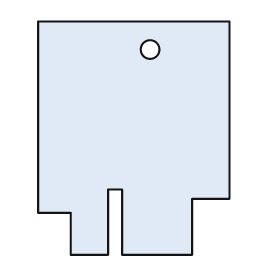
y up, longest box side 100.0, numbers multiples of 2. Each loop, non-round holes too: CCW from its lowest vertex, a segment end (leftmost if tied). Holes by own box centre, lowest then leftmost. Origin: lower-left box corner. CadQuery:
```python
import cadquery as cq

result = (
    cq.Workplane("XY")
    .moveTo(14.0, 0.0)
    .lineTo(30.0, 0.0)
    .lineTo(30.0, 28.0)
    .lineTo(36.0, 28.0)
    .lineTo(36.0, 0.0)
    .lineTo(66.0, 0.0)
    .lineTo(66.0, 24.0)
    .lineTo(82.0, 24.0)
    .lineTo(82.0, 100.0)
    .lineTo(0.0, 100.0)
    .lineTo(0.0, 18.0)
    .lineTo(14.0, 18.0)
    .close()
    .moveTo(48.0, 88.0)
    .circle(4.0)
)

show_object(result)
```